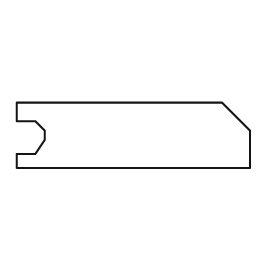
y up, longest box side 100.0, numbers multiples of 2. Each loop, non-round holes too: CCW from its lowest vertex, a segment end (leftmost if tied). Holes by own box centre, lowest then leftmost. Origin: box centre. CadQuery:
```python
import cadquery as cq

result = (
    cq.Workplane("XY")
    .moveTo(-50.0, -14.0)
    .lineTo(50.0, -14.0)
    .lineTo(50.0, 2.0)
    .lineTo(38.0, 14.0)
    .lineTo(-50.0, 14.0)
    .lineTo(-50.0, 6.0)
    .lineTo(-42.0, 6.0)
    .lineTo(-38.0, 2.0)
    .lineTo(-38.0, -2.0)
    .lineTo(-42.0, -8.0)
    .lineTo(-50.0, -8.0)
    .close()
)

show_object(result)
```